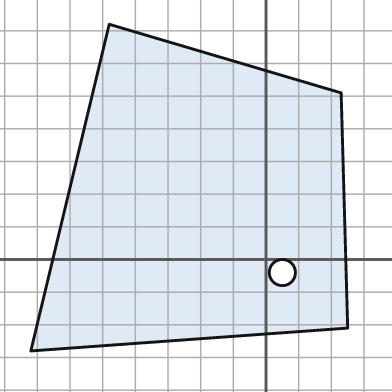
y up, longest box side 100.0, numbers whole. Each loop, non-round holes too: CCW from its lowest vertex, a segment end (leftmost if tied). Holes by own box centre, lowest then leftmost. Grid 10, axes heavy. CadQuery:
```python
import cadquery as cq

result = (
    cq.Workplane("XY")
    .moveTo(-72.0, -28.0)
    .lineTo(25.0, -21.0)
    .lineTo(23.0, 51.0)
    .lineTo(-48.0, 72.0)
    .close()
    .moveTo(5.0, -4.0)
    .circle(4.0)
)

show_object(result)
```